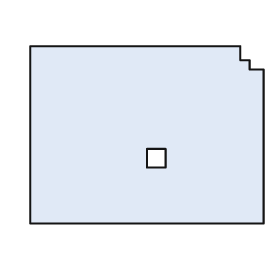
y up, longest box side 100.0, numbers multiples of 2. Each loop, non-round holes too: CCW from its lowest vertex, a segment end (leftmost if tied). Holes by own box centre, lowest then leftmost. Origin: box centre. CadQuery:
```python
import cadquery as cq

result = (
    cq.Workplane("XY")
    .moveTo(-50.0, -38.0)
    .lineTo(50.0, -38.0)
    .lineTo(50.0, 28.0)
    .lineTo(44.0, 28.0)
    .lineTo(44.0, 32.0)
    .lineTo(40.0, 32.0)
    .lineTo(40.0, 38.0)
    .lineTo(-50.0, 38.0)
    .close()
    .moveTo(0.0, -14.0)
    .lineTo(8.0, -14.0)
    .lineTo(8.0, -6.0)
    .lineTo(0.0, -6.0)
    .close()
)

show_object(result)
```